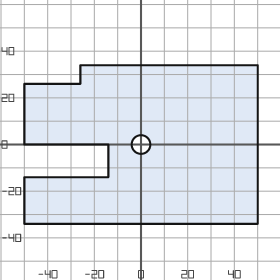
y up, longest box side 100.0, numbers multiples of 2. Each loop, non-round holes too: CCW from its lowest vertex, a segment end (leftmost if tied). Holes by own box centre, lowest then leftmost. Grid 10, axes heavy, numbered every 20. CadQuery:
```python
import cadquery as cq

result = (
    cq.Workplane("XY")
    .moveTo(-50.0, -34.0)
    .lineTo(50.0, -34.0)
    .lineTo(50.0, 34.0)
    .lineTo(-26.0, 34.0)
    .lineTo(-26.0, 26.0)
    .lineTo(-50.0, 26.0)
    .lineTo(-50.0, 0.0)
    .lineTo(-14.0, 0.0)
    .lineTo(-14.0, -14.0)
    .lineTo(-50.0, -14.0)
    .close()
    .moveTo(0.0, 0.0)
    .circle(4.0)
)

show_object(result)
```